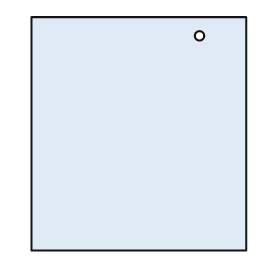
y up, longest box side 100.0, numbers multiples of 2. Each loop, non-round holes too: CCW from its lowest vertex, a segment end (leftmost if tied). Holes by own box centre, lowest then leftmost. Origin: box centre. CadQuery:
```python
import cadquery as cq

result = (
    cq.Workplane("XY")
    .moveTo(-46.0, -50.0)
    .lineTo(46.0, -50.0)
    .lineTo(46.0, 50.0)
    .lineTo(-46.0, 50.0)
    .close()
    .moveTo(26.0, 42.0)
    .circle(2.0)
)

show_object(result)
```